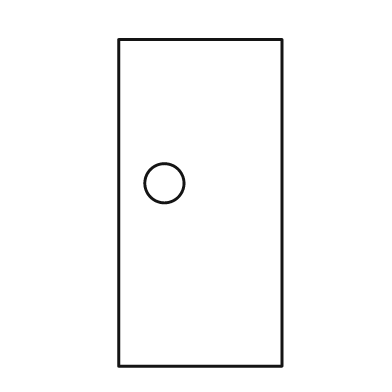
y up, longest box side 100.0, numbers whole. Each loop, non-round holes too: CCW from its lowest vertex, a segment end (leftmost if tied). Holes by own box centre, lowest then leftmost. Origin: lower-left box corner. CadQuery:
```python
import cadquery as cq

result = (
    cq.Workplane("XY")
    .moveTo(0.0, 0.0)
    .lineTo(50.0, 0.0)
    .lineTo(50.0, 100.0)
    .lineTo(0.0, 100.0)
    .close()
    .moveTo(14.0, 56.0)
    .circle(6.0)
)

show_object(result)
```